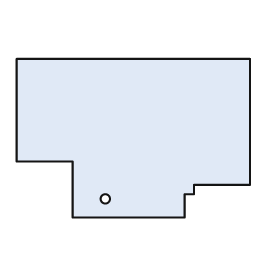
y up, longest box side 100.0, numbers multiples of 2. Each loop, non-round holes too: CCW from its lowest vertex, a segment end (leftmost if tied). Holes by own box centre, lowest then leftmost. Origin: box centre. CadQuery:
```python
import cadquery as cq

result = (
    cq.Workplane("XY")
    .moveTo(-26.0, -34.0)
    .lineTo(22.0, -34.0)
    .lineTo(22.0, -24.0)
    .lineTo(26.0, -24.0)
    .lineTo(26.0, -20.0)
    .lineTo(50.0, -20.0)
    .lineTo(50.0, 34.0)
    .lineTo(-50.0, 34.0)
    .lineTo(-50.0, -10.0)
    .lineTo(-26.0, -10.0)
    .close()
    .moveTo(-12.0, -26.0)
    .circle(2.0)
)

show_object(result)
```